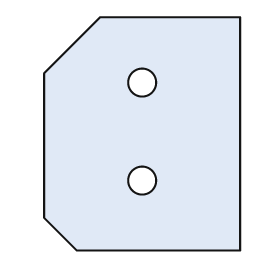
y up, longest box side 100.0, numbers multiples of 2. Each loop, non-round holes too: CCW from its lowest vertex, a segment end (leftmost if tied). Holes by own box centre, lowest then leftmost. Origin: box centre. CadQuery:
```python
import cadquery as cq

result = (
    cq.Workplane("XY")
    .moveTo(-28.0, -50.0)
    .lineTo(42.0, -50.0)
    .lineTo(42.0, 50.0)
    .lineTo(-18.0, 50.0)
    .lineTo(-42.0, 26.0)
    .lineTo(-42.0, -36.0)
    .close()
    .moveTo(0.0, -20.0)
    .circle(6.0)
    .moveTo(0.0, 22.0)
    .circle(6.0)
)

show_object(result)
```